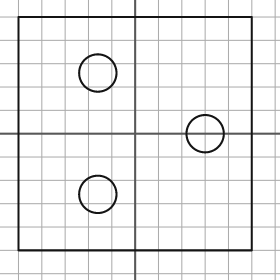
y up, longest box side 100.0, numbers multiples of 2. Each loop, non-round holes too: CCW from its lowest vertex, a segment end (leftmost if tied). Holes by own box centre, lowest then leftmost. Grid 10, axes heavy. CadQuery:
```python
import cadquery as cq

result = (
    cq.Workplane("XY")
    .moveTo(-50.0, -50.0)
    .lineTo(50.0, -50.0)
    .lineTo(50.0, 50.0)
    .lineTo(-50.0, 50.0)
    .close()
    .moveTo(-16.0, -26.0)
    .circle(8.0)
    .moveTo(30.0, 0.0)
    .circle(8.0)
    .moveTo(-16.0, 26.0)
    .circle(8.0)
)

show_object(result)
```